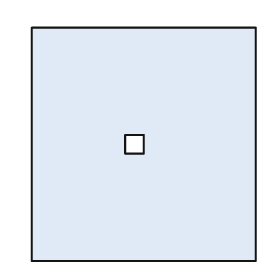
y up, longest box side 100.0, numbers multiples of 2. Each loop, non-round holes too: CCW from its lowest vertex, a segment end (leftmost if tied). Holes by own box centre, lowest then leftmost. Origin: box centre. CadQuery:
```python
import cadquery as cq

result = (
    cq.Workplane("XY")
    .moveTo(-48.0, -50.0)
    .lineTo(48.0, -50.0)
    .lineTo(48.0, 50.0)
    .lineTo(-48.0, 50.0)
    .close()
    .moveTo(-8.0, -4.0)
    .lineTo(0.0, -4.0)
    .lineTo(0.0, 4.0)
    .lineTo(-8.0, 4.0)
    .close()
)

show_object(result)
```